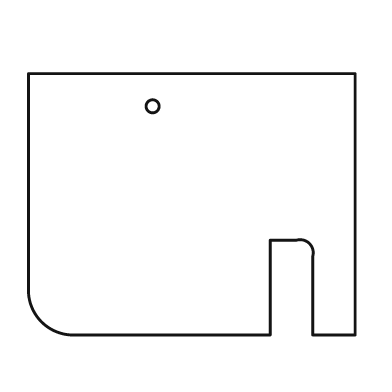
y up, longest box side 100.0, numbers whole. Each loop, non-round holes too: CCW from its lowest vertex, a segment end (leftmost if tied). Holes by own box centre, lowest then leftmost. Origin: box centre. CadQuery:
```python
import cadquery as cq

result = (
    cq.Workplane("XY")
    .moveTo(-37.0, -40.0)
    .lineTo(24.0, -40.0)
    .lineTo(24.0, -11.0)
    .lineTo(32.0, -11.0)
    .threePointArc((36.0, -12.0), (37.0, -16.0))
    .lineTo(37.0, -40.0)
    .lineTo(50.0, -40.0)
    .lineTo(50.0, 40.0)
    .lineTo(-50.0, 40.0)
    .lineTo(-50.0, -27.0)
    .threePointArc((-46.0, -36.0), (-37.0, -40.0))
    .close()
    .moveTo(-12.0, 30.0)
    .circle(2.0)
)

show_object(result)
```